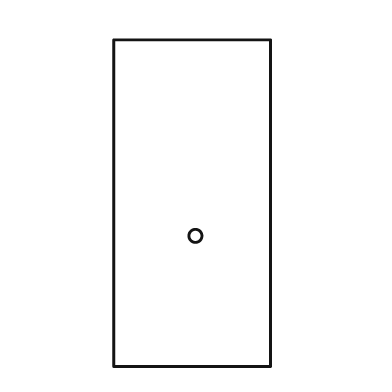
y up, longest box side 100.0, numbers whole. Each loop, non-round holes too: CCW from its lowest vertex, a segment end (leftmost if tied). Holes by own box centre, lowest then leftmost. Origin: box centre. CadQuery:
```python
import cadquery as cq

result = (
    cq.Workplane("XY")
    .moveTo(-24.0, -50.0)
    .lineTo(24.0, -50.0)
    .lineTo(24.0, 50.0)
    .lineTo(-24.0, 50.0)
    .close()
    .moveTo(1.0, -10.0)
    .circle(2.0)
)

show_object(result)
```